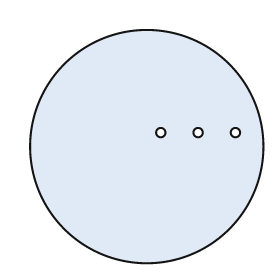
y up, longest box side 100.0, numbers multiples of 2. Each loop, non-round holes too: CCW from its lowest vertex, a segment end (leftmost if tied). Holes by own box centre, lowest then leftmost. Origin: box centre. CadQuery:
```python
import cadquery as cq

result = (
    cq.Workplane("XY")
    .moveTo(0.0, 0.0)
    .circle(50.0)
    .moveTo(6.0, 6.0)
    .circle(2.0)
    .moveTo(22.0, 6.0)
    .circle(2.0)
    .moveTo(38.0, 6.0)
    .circle(2.0)
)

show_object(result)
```